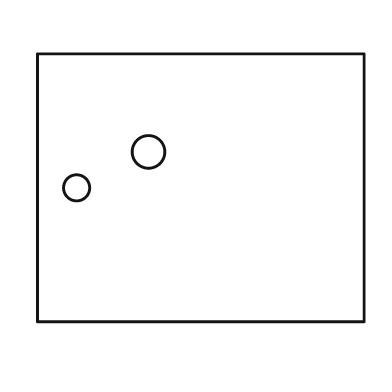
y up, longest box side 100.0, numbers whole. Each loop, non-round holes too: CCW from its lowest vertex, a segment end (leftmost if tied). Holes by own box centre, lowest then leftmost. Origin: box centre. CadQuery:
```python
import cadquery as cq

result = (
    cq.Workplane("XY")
    .moveTo(-50.0, -41.0)
    .lineTo(50.0, -41.0)
    .lineTo(50.0, 41.0)
    .lineTo(-50.0, 41.0)
    .close()
    .moveTo(-38.0, 0.0)
    .circle(4.0)
    .moveTo(-16.0, 11.0)
    .circle(5.0)
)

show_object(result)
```